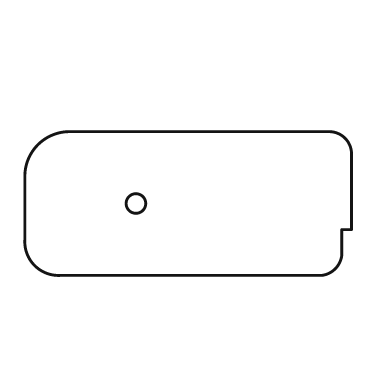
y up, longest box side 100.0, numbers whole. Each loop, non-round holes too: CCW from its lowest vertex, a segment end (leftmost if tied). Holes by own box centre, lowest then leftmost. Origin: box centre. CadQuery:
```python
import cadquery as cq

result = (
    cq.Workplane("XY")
    .moveTo(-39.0, -22.0)
    .lineTo(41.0, -22.0)
    .threePointArc((45.0, -20.0), (47.0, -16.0))
    .lineTo(47.0, -8.0)
    .lineTo(50.0, -8.0)
    .lineTo(50.0, 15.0)
    .threePointArc((48.0, 20.0), (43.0, 22.0))
    .lineTo(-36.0, 22.0)
    .threePointArc((-46.0, 18.0), (-50.0, 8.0))
    .lineTo(-50.0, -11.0)
    .threePointArc((-47.0, -19.0), (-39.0, -22.0))
    .close()
    .moveTo(-16.0, 0.0)
    .circle(3.0)
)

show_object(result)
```